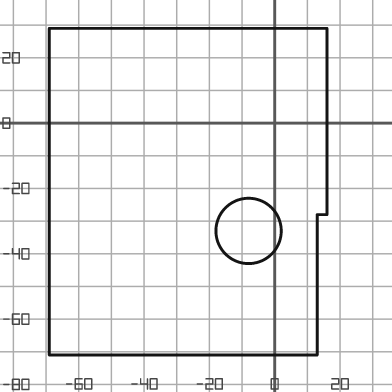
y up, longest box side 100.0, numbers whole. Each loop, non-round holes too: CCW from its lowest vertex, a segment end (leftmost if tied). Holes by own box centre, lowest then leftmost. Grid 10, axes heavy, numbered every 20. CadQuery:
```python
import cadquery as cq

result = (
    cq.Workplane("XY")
    .moveTo(-69.0, -71.0)
    .lineTo(13.0, -71.0)
    .lineTo(13.0, -28.0)
    .lineTo(16.0, -28.0)
    .lineTo(16.0, 29.0)
    .lineTo(-69.0, 29.0)
    .close()
    .moveTo(-8.0, -33.0)
    .circle(10.0)
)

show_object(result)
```